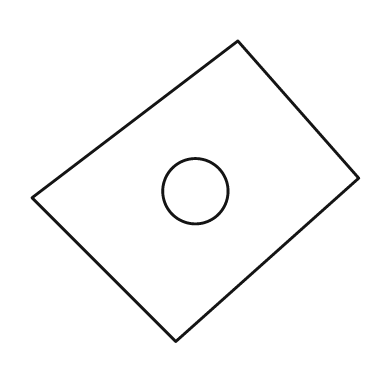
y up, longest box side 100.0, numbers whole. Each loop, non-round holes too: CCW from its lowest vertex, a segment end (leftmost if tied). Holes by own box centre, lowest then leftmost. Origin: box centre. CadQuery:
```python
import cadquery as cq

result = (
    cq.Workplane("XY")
    .moveTo(-6.0, -46.0)
    .lineTo(50.0, 4.0)
    .lineTo(13.0, 46.0)
    .lineTo(-50.0, -2.0)
    .close()
    .moveTo(0.0, 0.0)
    .circle(10.0)
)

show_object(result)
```